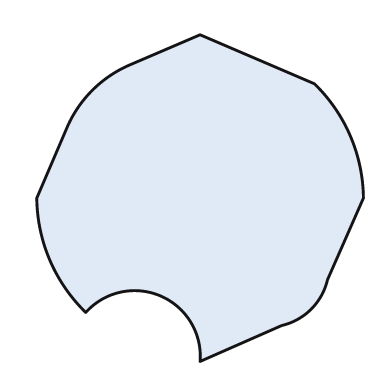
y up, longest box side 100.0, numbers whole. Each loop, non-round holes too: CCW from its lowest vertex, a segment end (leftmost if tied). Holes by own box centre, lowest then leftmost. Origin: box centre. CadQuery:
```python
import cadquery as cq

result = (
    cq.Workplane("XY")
    .moveTo(0.0, -50.0)
    .lineTo(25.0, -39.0)
    .threePointArc((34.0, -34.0), (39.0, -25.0))
    .lineTo(50.0, 0.0)
    .threePointArc((46.0, 19.0), (35.0, 35.0))
    .lineTo(0.0, 50.0)
    .lineTo(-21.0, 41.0)
    .threePointArc((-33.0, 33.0), (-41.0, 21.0))
    .lineTo(-50.0, 0.0)
    .threePointArc((-46.0, -19.0), (-35.0, -35.0))
    .threePointArc((-12.0, -30.0), (0.0, -50.0))
    .close()
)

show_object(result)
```